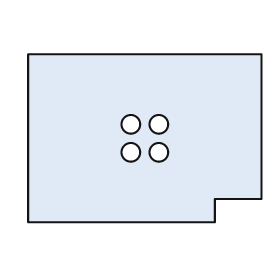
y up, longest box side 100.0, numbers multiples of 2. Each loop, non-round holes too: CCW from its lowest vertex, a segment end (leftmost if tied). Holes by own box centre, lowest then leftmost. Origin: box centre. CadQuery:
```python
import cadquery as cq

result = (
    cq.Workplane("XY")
    .moveTo(-50.0, -36.0)
    .lineTo(30.0, -36.0)
    .lineTo(30.0, -26.0)
    .lineTo(50.0, -26.0)
    .lineTo(50.0, 36.0)
    .lineTo(-50.0, 36.0)
    .close()
    .moveTo(-6.0, -6.0)
    .circle(4.0)
    .moveTo(6.0, -6.0)
    .circle(4.0)
    .moveTo(-6.0, 6.0)
    .circle(4.0)
    .moveTo(6.0, 6.0)
    .circle(4.0)
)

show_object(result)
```